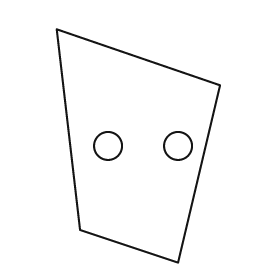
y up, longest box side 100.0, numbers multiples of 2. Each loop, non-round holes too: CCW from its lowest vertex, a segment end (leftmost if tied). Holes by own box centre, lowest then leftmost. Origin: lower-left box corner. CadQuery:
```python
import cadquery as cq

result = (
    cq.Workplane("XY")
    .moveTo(52.0, 0.0)
    .lineTo(70.0, 76.0)
    .lineTo(0.0, 100.0)
    .lineTo(10.0, 14.0)
    .close()
    .moveTo(22.0, 50.0)
    .circle(6.0)
    .moveTo(52.0, 50.0)
    .circle(6.0)
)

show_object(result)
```